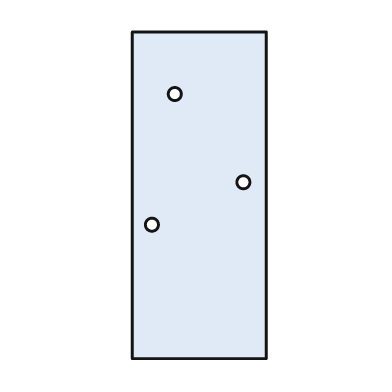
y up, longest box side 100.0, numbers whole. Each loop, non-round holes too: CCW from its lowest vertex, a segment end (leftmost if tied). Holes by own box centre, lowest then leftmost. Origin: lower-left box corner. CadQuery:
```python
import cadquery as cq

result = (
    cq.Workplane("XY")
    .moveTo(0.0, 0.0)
    .lineTo(41.0, 0.0)
    .lineTo(41.0, 100.0)
    .lineTo(0.0, 100.0)
    .close()
    .moveTo(6.0, 41.0)
    .circle(2.0)
    .moveTo(34.0, 54.0)
    .circle(2.0)
    .moveTo(13.0, 81.0)
    .circle(2.0)
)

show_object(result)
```